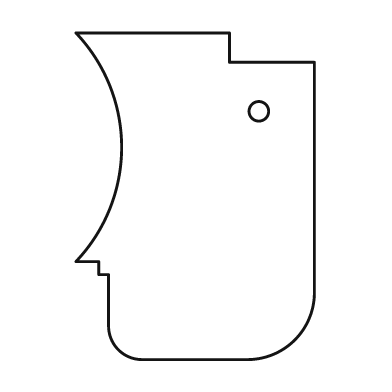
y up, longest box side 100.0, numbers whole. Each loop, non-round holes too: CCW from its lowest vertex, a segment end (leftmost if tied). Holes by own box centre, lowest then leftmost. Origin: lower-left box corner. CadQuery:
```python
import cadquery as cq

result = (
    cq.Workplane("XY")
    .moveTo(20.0, 0.0)
    .lineTo(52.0, 0.0)
    .threePointArc((67.0, 6.0), (73.0, 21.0))
    .lineTo(73.0, 91.0)
    .lineTo(47.0, 91.0)
    .lineTo(47.0, 100.0)
    .lineTo(0.0, 100.0)
    .threePointArc((14.0, 65.0), (0.0, 30.0))
    .lineTo(7.0, 30.0)
    .lineTo(7.0, 26.0)
    .lineTo(10.0, 26.0)
    .lineTo(10.0, 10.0)
    .threePointArc((13.0, 3.0), (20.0, 0.0))
    .close()
    .moveTo(56.0, 76.0)
    .circle(3.0)
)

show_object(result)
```